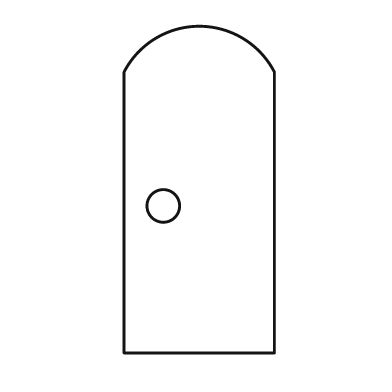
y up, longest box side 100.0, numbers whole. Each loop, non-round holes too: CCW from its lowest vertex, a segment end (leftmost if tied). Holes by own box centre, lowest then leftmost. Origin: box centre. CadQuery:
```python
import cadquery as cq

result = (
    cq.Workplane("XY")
    .moveTo(-23.0, -50.0)
    .lineTo(23.0, -50.0)
    .lineTo(23.0, 36.0)
    .threePointArc((0.0, 50.0), (-23.0, 36.0))
    .close()
    .moveTo(-11.0, -5.0)
    .circle(5.0)
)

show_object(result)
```